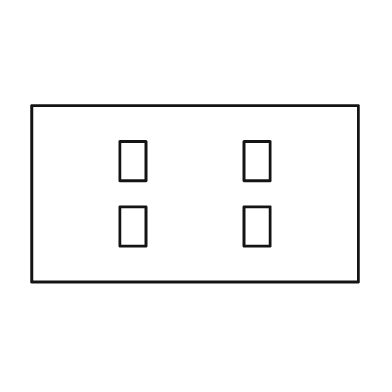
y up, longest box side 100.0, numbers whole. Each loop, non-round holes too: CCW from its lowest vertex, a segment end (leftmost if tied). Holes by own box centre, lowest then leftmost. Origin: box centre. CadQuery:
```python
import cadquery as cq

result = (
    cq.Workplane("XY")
    .moveTo(-50.0, -27.0)
    .lineTo(50.0, -27.0)
    .lineTo(50.0, 27.0)
    .lineTo(-50.0, 27.0)
    .close()
    .moveTo(-23.0, -16.0)
    .lineTo(-15.0, -16.0)
    .lineTo(-15.0, -4.0)
    .lineTo(-23.0, -4.0)
    .close()
    .moveTo(15.0, -16.0)
    .lineTo(23.0, -16.0)
    .lineTo(23.0, -4.0)
    .lineTo(15.0, -4.0)
    .close()
    .moveTo(-23.0, 4.0)
    .lineTo(-15.0, 4.0)
    .lineTo(-15.0, 16.0)
    .lineTo(-23.0, 16.0)
    .close()
    .moveTo(15.0, 4.0)
    .lineTo(23.0, 4.0)
    .lineTo(23.0, 16.0)
    .lineTo(15.0, 16.0)
    .close()
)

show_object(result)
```